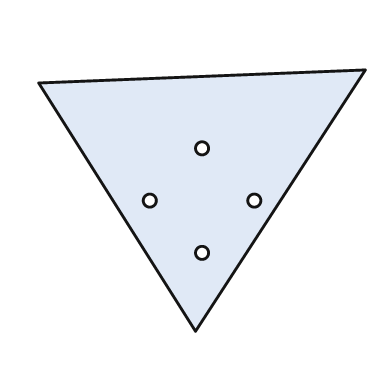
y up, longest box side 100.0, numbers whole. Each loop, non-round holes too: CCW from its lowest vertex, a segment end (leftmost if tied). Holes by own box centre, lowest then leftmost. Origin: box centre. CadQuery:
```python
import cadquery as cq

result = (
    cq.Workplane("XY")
    .moveTo(-2.0, -40.0)
    .lineTo(50.0, 40.0)
    .lineTo(-50.0, 36.0)
    .close()
    .moveTo(0.0, -16.0)
    .circle(2.0)
    .moveTo(-16.0, 0.0)
    .circle(2.0)
    .moveTo(16.0, 0.0)
    .circle(2.0)
    .moveTo(0.0, 16.0)
    .circle(2.0)
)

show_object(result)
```